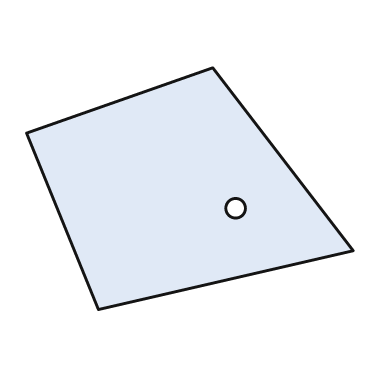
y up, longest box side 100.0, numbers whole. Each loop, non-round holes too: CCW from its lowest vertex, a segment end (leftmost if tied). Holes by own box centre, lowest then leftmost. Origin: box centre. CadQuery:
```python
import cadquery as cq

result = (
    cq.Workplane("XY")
    .moveTo(-28.0, -37.0)
    .lineTo(50.0, -19.0)
    .lineTo(7.0, 37.0)
    .lineTo(-50.0, 17.0)
    .close()
    .moveTo(14.0, -6.0)
    .circle(3.0)
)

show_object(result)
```